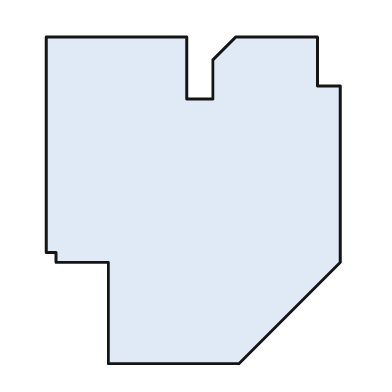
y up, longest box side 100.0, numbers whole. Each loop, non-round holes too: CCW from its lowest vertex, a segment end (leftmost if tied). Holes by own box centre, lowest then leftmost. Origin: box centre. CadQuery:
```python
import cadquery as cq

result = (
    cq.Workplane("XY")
    .moveTo(-26.0, -50.0)
    .lineTo(14.0, -50.0)
    .lineTo(45.0, -19.0)
    .lineTo(45.0, 35.0)
    .lineTo(38.0, 35.0)
    .lineTo(38.0, 50.0)
    .lineTo(13.0, 50.0)
    .lineTo(6.0, 43.0)
    .lineTo(6.0, 31.0)
    .lineTo(-2.0, 31.0)
    .lineTo(-2.0, 50.0)
    .lineTo(-45.0, 50.0)
    .lineTo(-45.0, -16.0)
    .lineTo(-42.0, -16.0)
    .lineTo(-42.0, -19.0)
    .lineTo(-26.0, -19.0)
    .close()
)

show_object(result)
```